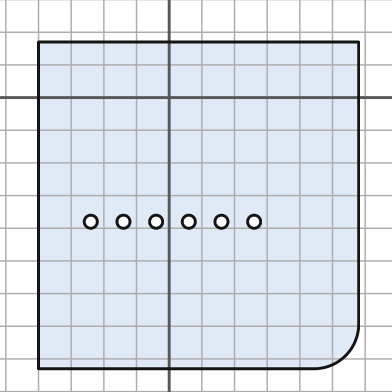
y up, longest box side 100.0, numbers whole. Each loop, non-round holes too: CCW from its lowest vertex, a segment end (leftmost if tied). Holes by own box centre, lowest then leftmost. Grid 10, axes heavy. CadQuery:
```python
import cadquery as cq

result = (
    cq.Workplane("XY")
    .moveTo(-40.0, -83.0)
    .lineTo(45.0, -83.0)
    .threePointArc((54.0, -79.0), (58.0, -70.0))
    .lineTo(58.0, 17.0)
    .lineTo(-40.0, 17.0)
    .close()
    .moveTo(-24.0, -38.0)
    .circle(2.0)
    .moveTo(-14.0, -38.0)
    .circle(2.0)
    .moveTo(-4.0, -38.0)
    .circle(2.0)
    .moveTo(6.0, -38.0)
    .circle(2.0)
    .moveTo(16.0, -38.0)
    .circle(2.0)
    .moveTo(26.0, -38.0)
    .circle(2.0)
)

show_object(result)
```